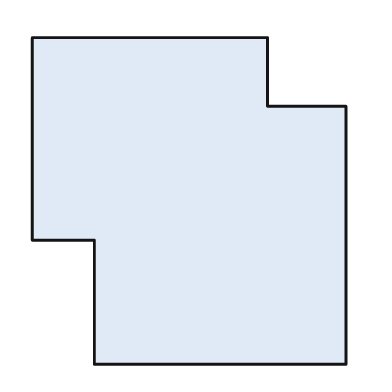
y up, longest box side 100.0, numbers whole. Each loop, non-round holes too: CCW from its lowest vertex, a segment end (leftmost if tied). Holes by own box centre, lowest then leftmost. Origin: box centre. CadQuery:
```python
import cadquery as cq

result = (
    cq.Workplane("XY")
    .moveTo(-29.0, -50.0)
    .lineTo(48.0, -50.0)
    .lineTo(48.0, 29.0)
    .lineTo(24.0, 29.0)
    .lineTo(24.0, 50.0)
    .lineTo(-48.0, 50.0)
    .lineTo(-48.0, -12.0)
    .lineTo(-29.0, -12.0)
    .close()
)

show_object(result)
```